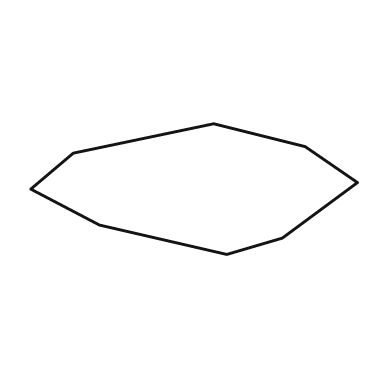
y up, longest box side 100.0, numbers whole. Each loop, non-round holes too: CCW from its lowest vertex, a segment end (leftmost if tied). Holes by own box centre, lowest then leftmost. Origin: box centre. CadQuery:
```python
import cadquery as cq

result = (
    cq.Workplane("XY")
    .moveTo(10.0, -20.0)
    .lineTo(27.0, -15.0)
    .lineTo(50.0, 2.0)
    .lineTo(34.0, 13.0)
    .lineTo(6.0, 20.0)
    .lineTo(-37.0, 11.0)
    .lineTo(-50.0, 0.0)
    .lineTo(-29.0, -11.0)
    .close()
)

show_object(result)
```